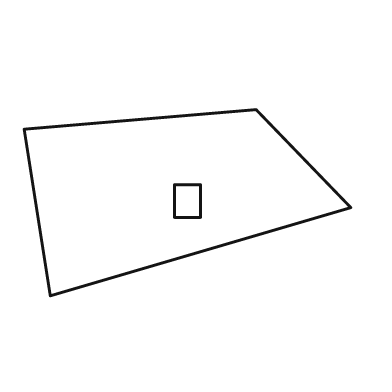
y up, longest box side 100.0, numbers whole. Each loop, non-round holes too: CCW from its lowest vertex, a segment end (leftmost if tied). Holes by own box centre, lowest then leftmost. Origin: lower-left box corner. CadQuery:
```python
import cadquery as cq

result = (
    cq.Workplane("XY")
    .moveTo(8.0, 0.0)
    .lineTo(100.0, 27.0)
    .lineTo(71.0, 57.0)
    .lineTo(0.0, 51.0)
    .close()
    .moveTo(46.0, 24.0)
    .lineTo(54.0, 24.0)
    .lineTo(54.0, 34.0)
    .lineTo(46.0, 34.0)
    .close()
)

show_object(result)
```